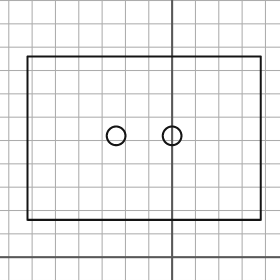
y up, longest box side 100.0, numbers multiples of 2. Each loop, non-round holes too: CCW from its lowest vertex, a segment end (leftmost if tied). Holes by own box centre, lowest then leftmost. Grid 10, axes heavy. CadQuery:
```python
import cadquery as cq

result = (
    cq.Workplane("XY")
    .moveTo(-62.0, 16.0)
    .lineTo(38.0, 16.0)
    .lineTo(38.0, 86.0)
    .lineTo(-62.0, 86.0)
    .close()
    .moveTo(-24.0, 52.0)
    .circle(4.0)
    .moveTo(0.0, 52.0)
    .circle(4.0)
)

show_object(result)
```